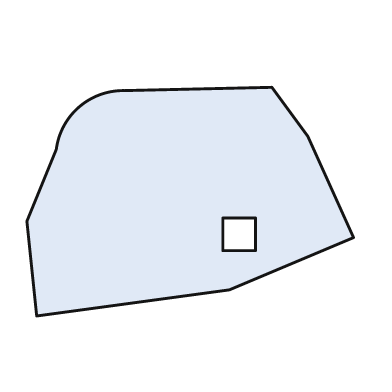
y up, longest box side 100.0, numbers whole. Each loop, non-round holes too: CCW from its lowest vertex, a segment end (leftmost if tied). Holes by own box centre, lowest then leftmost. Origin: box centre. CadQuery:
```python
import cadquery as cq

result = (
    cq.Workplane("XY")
    .moveTo(-47.0, -35.0)
    .lineTo(12.0, -27.0)
    .lineTo(50.0, -11.0)
    .lineTo(36.0, 20.0)
    .lineTo(25.0, 35.0)
    .lineTo(-20.0, 34.0)
    .threePointArc((-34.0, 29.0), (-41.0, 16.0))
    .lineTo(-50.0, -6.0)
    .close()
    .moveTo(10.0, -15.0)
    .lineTo(20.0, -15.0)
    .lineTo(20.0, -5.0)
    .lineTo(10.0, -5.0)
    .close()
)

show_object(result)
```